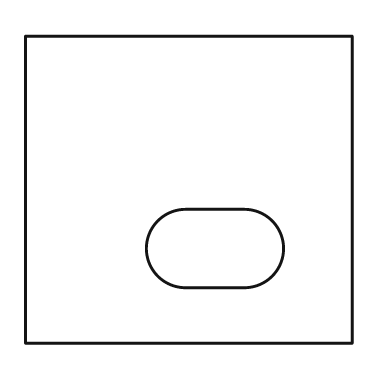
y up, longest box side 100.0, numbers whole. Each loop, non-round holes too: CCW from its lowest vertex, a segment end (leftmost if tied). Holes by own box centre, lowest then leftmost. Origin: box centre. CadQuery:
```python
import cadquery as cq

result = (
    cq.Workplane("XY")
    .moveTo(-50.0, -47.0)
    .lineTo(50.0, -47.0)
    .lineTo(50.0, 47.0)
    .lineTo(-50.0, 47.0)
    .close()
    .moveTo(-1.0, -30.0)
    .lineTo(17.0, -30.0)
    .threePointArc((29.0, -18.0), (17.0, -6.0))
    .lineTo(-1.0, -6.0)
    .threePointArc((-13.0, -18.0), (-1.0, -30.0))
    .close()
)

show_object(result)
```